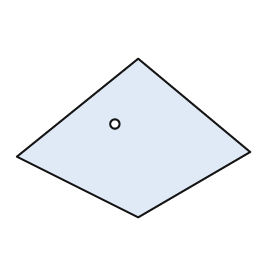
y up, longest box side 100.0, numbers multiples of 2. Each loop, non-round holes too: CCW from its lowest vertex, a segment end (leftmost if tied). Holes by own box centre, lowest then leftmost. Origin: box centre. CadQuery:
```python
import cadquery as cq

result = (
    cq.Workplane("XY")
    .moveTo(2.0, -34.0)
    .lineTo(50.0, -6.0)
    .lineTo(2.0, 34.0)
    .lineTo(-50.0, -8.0)
    .close()
    .moveTo(-8.0, 6.0)
    .circle(2.0)
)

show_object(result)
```